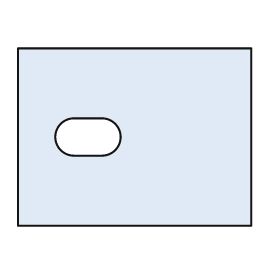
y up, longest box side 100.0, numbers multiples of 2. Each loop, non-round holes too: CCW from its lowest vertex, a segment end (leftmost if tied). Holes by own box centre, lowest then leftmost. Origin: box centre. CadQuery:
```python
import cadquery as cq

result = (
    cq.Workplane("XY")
    .moveTo(-50.0, -38.0)
    .lineTo(50.0, -38.0)
    .lineTo(50.0, 38.0)
    .lineTo(-50.0, 38.0)
    .close()
    .moveTo(-26.0, -8.0)
    .lineTo(-14.0, -8.0)
    .threePointArc((-6.0, 0.0), (-14.0, 8.0))
    .lineTo(-26.0, 8.0)
    .threePointArc((-34.0, 0.0), (-26.0, -8.0))
    .close()
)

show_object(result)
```